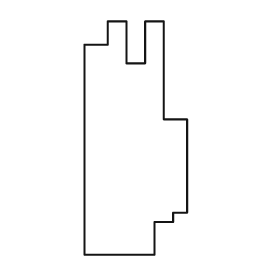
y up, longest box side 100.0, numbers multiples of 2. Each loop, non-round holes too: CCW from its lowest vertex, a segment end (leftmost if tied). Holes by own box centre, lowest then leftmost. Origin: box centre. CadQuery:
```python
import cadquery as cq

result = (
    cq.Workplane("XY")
    .moveTo(-22.0, -50.0)
    .lineTo(8.0, -50.0)
    .lineTo(8.0, -36.0)
    .lineTo(16.0, -36.0)
    .lineTo(16.0, -32.0)
    .lineTo(22.0, -32.0)
    .lineTo(22.0, 8.0)
    .lineTo(12.0, 8.0)
    .lineTo(12.0, 50.0)
    .lineTo(4.0, 50.0)
    .lineTo(4.0, 32.0)
    .lineTo(-4.0, 32.0)
    .lineTo(-4.0, 50.0)
    .lineTo(-12.0, 50.0)
    .lineTo(-12.0, 40.0)
    .lineTo(-22.0, 40.0)
    .close()
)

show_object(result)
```